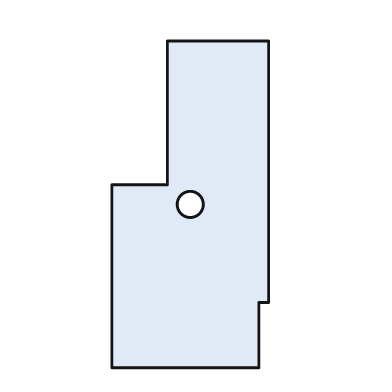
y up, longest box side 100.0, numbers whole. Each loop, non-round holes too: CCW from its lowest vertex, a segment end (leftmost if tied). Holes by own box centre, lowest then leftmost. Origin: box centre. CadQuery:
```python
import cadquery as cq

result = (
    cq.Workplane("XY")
    .moveTo(-24.0, -50.0)
    .lineTo(21.0, -50.0)
    .lineTo(21.0, -30.0)
    .lineTo(24.0, -30.0)
    .lineTo(24.0, 50.0)
    .lineTo(-7.0, 50.0)
    .lineTo(-7.0, 6.0)
    .lineTo(-24.0, 6.0)
    .close()
    .moveTo(0.0, 0.0)
    .circle(4.0)
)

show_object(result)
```